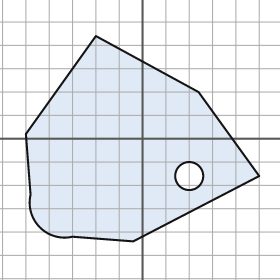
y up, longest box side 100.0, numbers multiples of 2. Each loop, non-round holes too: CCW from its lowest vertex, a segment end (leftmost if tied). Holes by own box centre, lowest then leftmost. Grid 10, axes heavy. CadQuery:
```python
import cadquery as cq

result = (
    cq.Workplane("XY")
    .moveTo(-4.0, -44.0)
    .lineTo(50.0, -16.0)
    .lineTo(24.0, 20.0)
    .lineTo(-20.0, 44.0)
    .lineTo(-50.0, 2.0)
    .lineTo(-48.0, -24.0)
    .threePointArc((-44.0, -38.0), (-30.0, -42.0))
    .close()
    .moveTo(20.0, -16.0)
    .circle(6.0)
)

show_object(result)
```